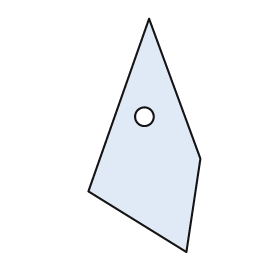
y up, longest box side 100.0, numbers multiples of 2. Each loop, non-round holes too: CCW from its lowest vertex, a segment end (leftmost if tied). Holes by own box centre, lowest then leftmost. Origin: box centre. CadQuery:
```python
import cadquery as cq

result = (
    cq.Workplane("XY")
    .moveTo(18.0, -50.0)
    .lineTo(24.0, -10.0)
    .lineTo(2.0, 50.0)
    .lineTo(-24.0, -24.0)
    .close()
    .moveTo(0.0, 8.0)
    .circle(4.0)
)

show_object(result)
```